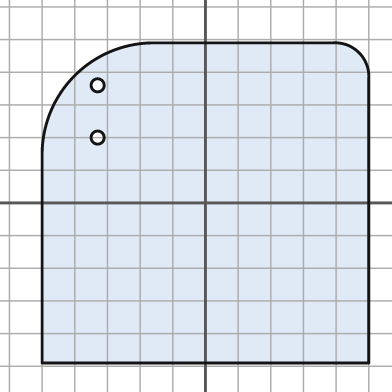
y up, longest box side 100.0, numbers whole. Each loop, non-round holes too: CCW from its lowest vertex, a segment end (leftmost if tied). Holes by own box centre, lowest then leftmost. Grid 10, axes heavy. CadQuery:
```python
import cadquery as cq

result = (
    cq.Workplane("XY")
    .moveTo(-50.0, -49.0)
    .lineTo(50.0, -49.0)
    .lineTo(50.0, 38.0)
    .threePointArc((47.0, 46.0), (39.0, 49.0))
    .lineTo(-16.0, 49.0)
    .threePointArc((-40.0, 39.0), (-50.0, 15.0))
    .close()
    .moveTo(-33.0, 20.0)
    .circle(2.0)
    .moveTo(-33.0, 36.0)
    .circle(2.0)
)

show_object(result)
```